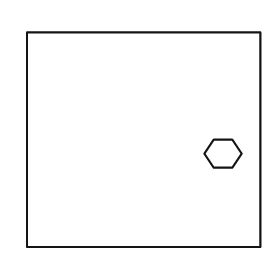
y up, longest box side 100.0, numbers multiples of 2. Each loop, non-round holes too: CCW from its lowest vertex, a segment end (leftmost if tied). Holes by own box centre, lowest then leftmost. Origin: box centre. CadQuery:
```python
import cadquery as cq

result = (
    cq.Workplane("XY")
    .moveTo(-50.0, -46.0)
    .lineTo(50.0, -46.0)
    .lineTo(50.0, 46.0)
    .lineTo(-50.0, 46.0)
    .close()
    .moveTo(30.0, -12.0)
    .lineTo(38.0, -12.0)
    .lineTo(42.0, -6.0)
    .lineTo(38.0, 0.0)
    .lineTo(30.0, 0.0)
    .lineTo(26.0, -6.0)
    .close()
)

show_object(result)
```